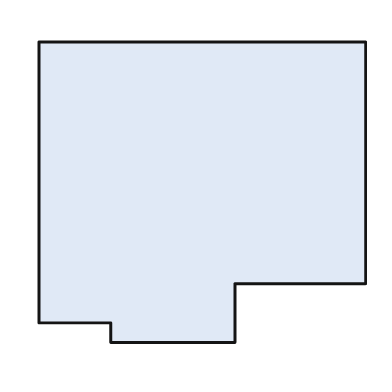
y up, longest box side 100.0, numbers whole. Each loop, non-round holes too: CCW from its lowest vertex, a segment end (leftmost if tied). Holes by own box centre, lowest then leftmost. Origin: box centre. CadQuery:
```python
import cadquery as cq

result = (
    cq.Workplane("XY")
    .moveTo(-28.0, -46.0)
    .lineTo(10.0, -46.0)
    .lineTo(10.0, -28.0)
    .lineTo(50.0, -28.0)
    .lineTo(50.0, 46.0)
    .lineTo(-50.0, 46.0)
    .lineTo(-50.0, -40.0)
    .lineTo(-28.0, -40.0)
    .close()
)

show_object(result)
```